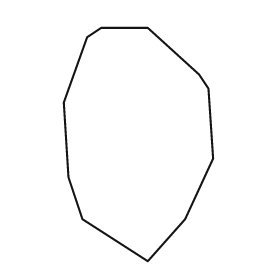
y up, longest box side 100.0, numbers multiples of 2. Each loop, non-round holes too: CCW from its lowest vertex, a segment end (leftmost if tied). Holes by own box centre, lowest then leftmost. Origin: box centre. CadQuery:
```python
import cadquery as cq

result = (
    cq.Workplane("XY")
    .moveTo(4.0, -50.0)
    .lineTo(20.0, -32.0)
    .lineTo(32.0, -6.0)
    .lineTo(30.0, 24.0)
    .lineTo(26.0, 30.0)
    .lineTo(4.0, 50.0)
    .lineTo(-16.0, 50.0)
    .lineTo(-22.0, 46.0)
    .lineTo(-32.0, 18.0)
    .lineTo(-30.0, -14.0)
    .lineTo(-24.0, -32.0)
    .close()
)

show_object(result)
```